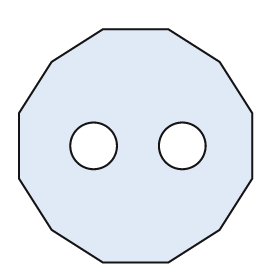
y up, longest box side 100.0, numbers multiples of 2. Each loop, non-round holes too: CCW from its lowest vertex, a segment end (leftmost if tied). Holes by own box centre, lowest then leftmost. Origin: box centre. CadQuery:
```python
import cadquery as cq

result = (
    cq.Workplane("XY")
    .moveTo(-14.0, -50.0)
    .lineTo(14.0, -50.0)
    .lineTo(36.0, -36.0)
    .lineTo(50.0, -14.0)
    .lineTo(50.0, 14.0)
    .lineTo(36.0, 36.0)
    .lineTo(14.0, 50.0)
    .lineTo(-14.0, 50.0)
    .lineTo(-36.0, 36.0)
    .lineTo(-50.0, 14.0)
    .lineTo(-50.0, -14.0)
    .lineTo(-36.0, -36.0)
    .close()
    .moveTo(-18.0, 0.0)
    .circle(10.0)
    .moveTo(20.0, 0.0)
    .circle(10.0)
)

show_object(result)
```